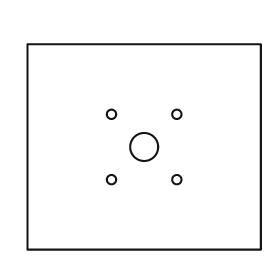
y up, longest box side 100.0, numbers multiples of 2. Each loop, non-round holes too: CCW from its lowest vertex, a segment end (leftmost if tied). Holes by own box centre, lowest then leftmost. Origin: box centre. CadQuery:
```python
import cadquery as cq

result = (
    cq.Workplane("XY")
    .moveTo(-50.0, -44.0)
    .lineTo(50.0, -44.0)
    .lineTo(50.0, 44.0)
    .lineTo(-50.0, 44.0)
    .close()
    .moveTo(-14.0, -14.0)
    .circle(2.0)
    .moveTo(14.0, -14.0)
    .circle(2.0)
    .moveTo(0.0, 0.0)
    .circle(6.0)
    .moveTo(-14.0, 14.0)
    .circle(2.0)
    .moveTo(14.0, 14.0)
    .circle(2.0)
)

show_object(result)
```